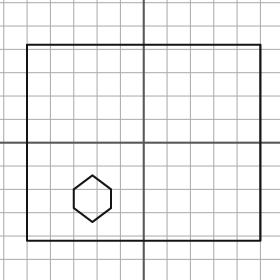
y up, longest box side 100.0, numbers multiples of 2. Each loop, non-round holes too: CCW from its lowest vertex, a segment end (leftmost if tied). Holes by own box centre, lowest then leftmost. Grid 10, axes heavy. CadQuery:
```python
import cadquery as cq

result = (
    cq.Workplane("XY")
    .moveTo(-50.0, -42.0)
    .lineTo(50.0, -42.0)
    .lineTo(50.0, 42.0)
    .lineTo(-50.0, 42.0)
    .close()
    .moveTo(-22.0, -34.0)
    .lineTo(-14.0, -28.0)
    .lineTo(-14.0, -20.0)
    .lineTo(-22.0, -14.0)
    .lineTo(-30.0, -20.0)
    .lineTo(-30.0, -28.0)
    .close()
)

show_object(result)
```